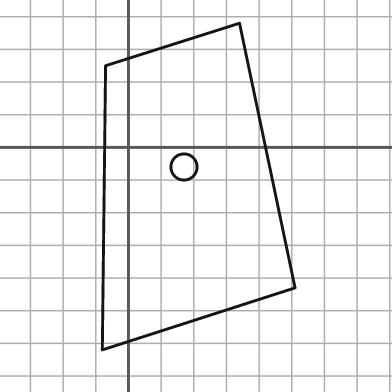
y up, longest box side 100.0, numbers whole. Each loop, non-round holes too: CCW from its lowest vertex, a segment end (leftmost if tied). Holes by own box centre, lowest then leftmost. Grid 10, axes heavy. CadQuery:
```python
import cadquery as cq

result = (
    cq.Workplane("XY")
    .moveTo(-8.0, -62.0)
    .lineTo(51.0, -43.0)
    .lineTo(34.0, 38.0)
    .lineTo(-7.0, 25.0)
    .close()
    .moveTo(17.0, -6.0)
    .circle(4.0)
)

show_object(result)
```